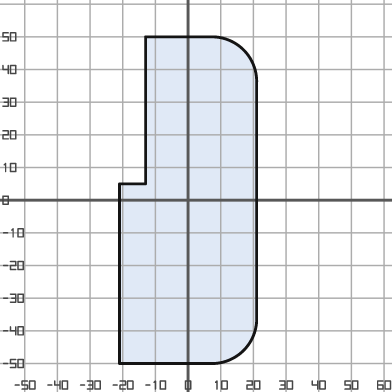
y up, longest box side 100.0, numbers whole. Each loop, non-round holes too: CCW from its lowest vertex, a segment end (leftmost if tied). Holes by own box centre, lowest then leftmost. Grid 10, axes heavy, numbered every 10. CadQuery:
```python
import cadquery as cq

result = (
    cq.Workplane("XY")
    .moveTo(-21.0, -50.0)
    .lineTo(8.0, -50.0)
    .threePointArc((17.0, -46.0), (21.0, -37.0))
    .lineTo(21.0, 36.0)
    .threePointArc((17.0, 46.0), (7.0, 50.0))
    .lineTo(-13.0, 50.0)
    .lineTo(-13.0, 5.0)
    .lineTo(-21.0, 5.0)
    .close()
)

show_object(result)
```